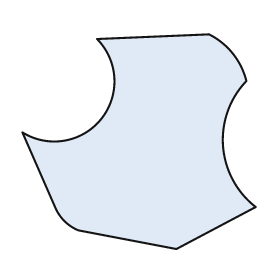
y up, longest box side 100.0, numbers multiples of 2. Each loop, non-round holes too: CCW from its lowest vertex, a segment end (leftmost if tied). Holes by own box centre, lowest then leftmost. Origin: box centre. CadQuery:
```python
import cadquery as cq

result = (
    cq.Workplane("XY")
    .moveTo(16.0, -46.0)
    .lineTo(50.0, -28.0)
    .threePointArc((36.0, -2.0), (46.0, 26.0))
    .threePointArc((40.0, 38.0), (30.0, 46.0))
    .lineTo(-18.0, 44.0)
    .threePointArc((-16.0, 10.0), (-50.0, 4.0))
    .lineTo(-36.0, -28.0)
    .threePointArc((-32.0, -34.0), (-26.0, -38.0))
    .close()
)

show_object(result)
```